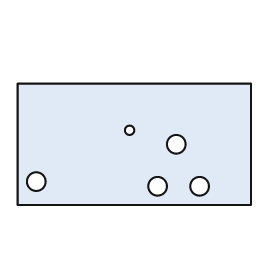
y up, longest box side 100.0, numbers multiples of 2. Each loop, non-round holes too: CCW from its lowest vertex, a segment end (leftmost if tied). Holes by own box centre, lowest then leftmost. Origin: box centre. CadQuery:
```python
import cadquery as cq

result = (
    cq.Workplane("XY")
    .moveTo(-50.0, -26.0)
    .lineTo(50.0, -26.0)
    .lineTo(50.0, 26.0)
    .lineTo(-50.0, 26.0)
    .close()
    .moveTo(10.0, -18.0)
    .circle(4.0)
    .moveTo(28.0, -18.0)
    .circle(4.0)
    .moveTo(-42.0, -16.0)
    .circle(4.0)
    .moveTo(18.0, 0.0)
    .circle(4.0)
    .moveTo(-2.0, 6.0)
    .circle(2.0)
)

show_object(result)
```